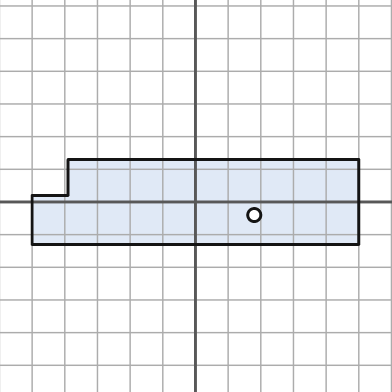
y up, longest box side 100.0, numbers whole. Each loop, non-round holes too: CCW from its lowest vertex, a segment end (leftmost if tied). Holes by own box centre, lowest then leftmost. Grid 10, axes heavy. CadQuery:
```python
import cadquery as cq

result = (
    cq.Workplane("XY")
    .moveTo(-50.0, -13.0)
    .lineTo(50.0, -13.0)
    .lineTo(50.0, 13.0)
    .lineTo(-39.0, 13.0)
    .lineTo(-39.0, 2.0)
    .lineTo(-50.0, 2.0)
    .close()
    .moveTo(18.0, -4.0)
    .circle(2.0)
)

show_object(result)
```